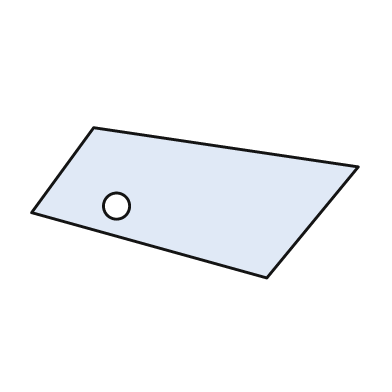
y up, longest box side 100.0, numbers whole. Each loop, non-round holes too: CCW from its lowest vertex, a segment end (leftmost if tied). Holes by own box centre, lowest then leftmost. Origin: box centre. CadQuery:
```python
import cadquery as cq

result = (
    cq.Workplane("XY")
    .moveTo(22.0, -23.0)
    .lineTo(50.0, 11.0)
    .lineTo(-31.0, 23.0)
    .lineTo(-50.0, -3.0)
    .close()
    .moveTo(-24.0, -1.0)
    .circle(4.0)
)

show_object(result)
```